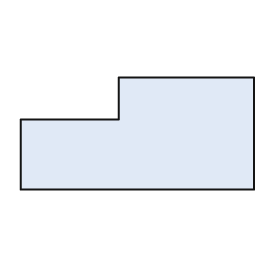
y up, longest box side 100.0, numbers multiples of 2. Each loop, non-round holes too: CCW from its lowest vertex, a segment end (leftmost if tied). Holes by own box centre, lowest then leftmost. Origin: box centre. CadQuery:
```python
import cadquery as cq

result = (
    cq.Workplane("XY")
    .moveTo(-50.0, -24.0)
    .lineTo(50.0, -24.0)
    .lineTo(50.0, 24.0)
    .lineTo(-8.0, 24.0)
    .lineTo(-8.0, 6.0)
    .lineTo(-50.0, 6.0)
    .close()
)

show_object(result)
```